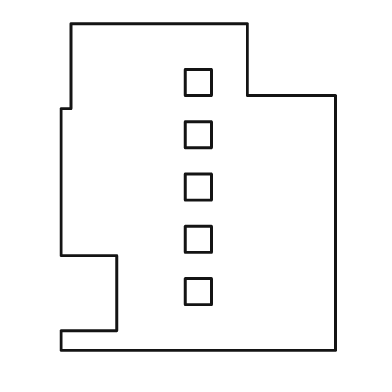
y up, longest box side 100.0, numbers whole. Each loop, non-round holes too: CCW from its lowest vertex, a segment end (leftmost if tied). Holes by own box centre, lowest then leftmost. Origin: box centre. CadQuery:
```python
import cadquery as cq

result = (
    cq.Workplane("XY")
    .moveTo(-42.0, -50.0)
    .lineTo(42.0, -50.0)
    .lineTo(42.0, 28.0)
    .lineTo(15.0, 28.0)
    .lineTo(15.0, 50.0)
    .lineTo(-39.0, 50.0)
    .lineTo(-39.0, 24.0)
    .lineTo(-42.0, 24.0)
    .lineTo(-42.0, -21.0)
    .lineTo(-25.0, -21.0)
    .lineTo(-25.0, -44.0)
    .lineTo(-42.0, -44.0)
    .close()
    .moveTo(-4.0, -36.0)
    .lineTo(4.0, -36.0)
    .lineTo(4.0, -28.0)
    .lineTo(-4.0, -28.0)
    .close()
    .moveTo(-4.0, -20.0)
    .lineTo(4.0, -20.0)
    .lineTo(4.0, -12.0)
    .lineTo(-4.0, -12.0)
    .close()
    .moveTo(-4.0, -4.0)
    .lineTo(4.0, -4.0)
    .lineTo(4.0, 4.0)
    .lineTo(-4.0, 4.0)
    .close()
    .moveTo(-4.0, 12.0)
    .lineTo(4.0, 12.0)
    .lineTo(4.0, 20.0)
    .lineTo(-4.0, 20.0)
    .close()
    .moveTo(-4.0, 28.0)
    .lineTo(4.0, 28.0)
    .lineTo(4.0, 36.0)
    .lineTo(-4.0, 36.0)
    .close()
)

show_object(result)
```